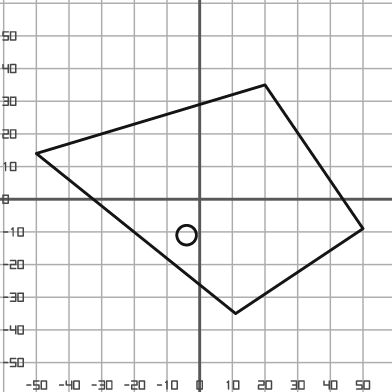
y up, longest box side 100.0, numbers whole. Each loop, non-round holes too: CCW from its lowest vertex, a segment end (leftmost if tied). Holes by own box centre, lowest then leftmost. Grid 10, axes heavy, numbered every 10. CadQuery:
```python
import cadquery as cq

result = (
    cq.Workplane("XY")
    .moveTo(11.0, -35.0)
    .lineTo(50.0, -9.0)
    .lineTo(20.0, 35.0)
    .lineTo(-50.0, 14.0)
    .close()
    .moveTo(-4.0, -11.0)
    .circle(3.0)
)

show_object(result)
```